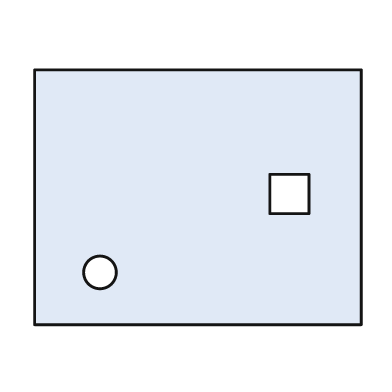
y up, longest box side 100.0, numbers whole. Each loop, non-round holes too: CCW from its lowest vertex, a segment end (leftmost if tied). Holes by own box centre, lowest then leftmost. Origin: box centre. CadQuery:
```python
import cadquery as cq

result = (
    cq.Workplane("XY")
    .moveTo(-50.0, -39.0)
    .lineTo(50.0, -39.0)
    .lineTo(50.0, 39.0)
    .lineTo(-50.0, 39.0)
    .close()
    .moveTo(-30.0, -23.0)
    .circle(5.0)
    .moveTo(22.0, -5.0)
    .lineTo(34.0, -5.0)
    .lineTo(34.0, 7.0)
    .lineTo(22.0, 7.0)
    .close()
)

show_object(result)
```